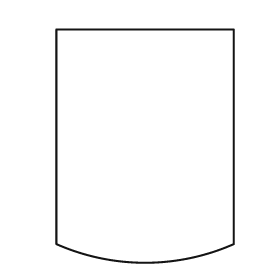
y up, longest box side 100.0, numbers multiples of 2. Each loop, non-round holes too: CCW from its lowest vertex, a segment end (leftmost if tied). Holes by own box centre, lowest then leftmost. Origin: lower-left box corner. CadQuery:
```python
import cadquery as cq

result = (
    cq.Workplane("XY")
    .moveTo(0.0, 8.0)
    .threePointArc((38.0, 0.0), (76.0, 8.0))
    .lineTo(76.0, 100.0)
    .lineTo(0.0, 100.0)
    .close()
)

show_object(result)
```